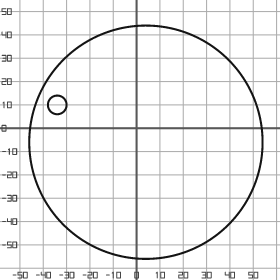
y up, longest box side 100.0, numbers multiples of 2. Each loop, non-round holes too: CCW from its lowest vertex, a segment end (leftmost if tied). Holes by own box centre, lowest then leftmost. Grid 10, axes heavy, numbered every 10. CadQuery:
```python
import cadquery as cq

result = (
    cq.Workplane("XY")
    .moveTo(4.0, -6.0)
    .circle(50.0)
    .moveTo(-34.0, 10.0)
    .circle(4.0)
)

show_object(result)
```